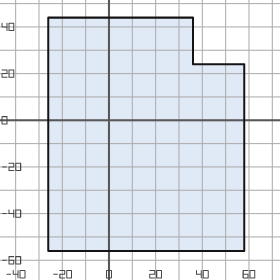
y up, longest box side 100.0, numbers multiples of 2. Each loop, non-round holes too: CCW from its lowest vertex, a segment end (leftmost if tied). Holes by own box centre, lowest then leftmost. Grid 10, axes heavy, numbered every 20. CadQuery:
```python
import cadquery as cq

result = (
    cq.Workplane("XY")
    .moveTo(-26.0, -56.0)
    .lineTo(58.0, -56.0)
    .lineTo(58.0, 24.0)
    .lineTo(36.0, 24.0)
    .lineTo(36.0, 44.0)
    .lineTo(-26.0, 44.0)
    .close()
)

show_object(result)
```